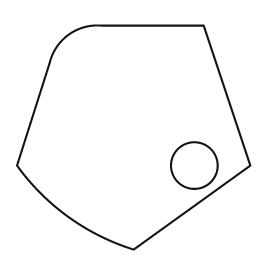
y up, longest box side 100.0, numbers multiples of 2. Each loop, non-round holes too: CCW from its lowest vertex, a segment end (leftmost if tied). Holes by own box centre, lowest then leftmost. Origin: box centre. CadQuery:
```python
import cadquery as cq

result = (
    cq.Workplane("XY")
    .moveTo(0.0, -48.0)
    .lineTo(50.0, -12.0)
    .lineTo(30.0, 48.0)
    .lineTo(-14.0, 48.0)
    .threePointArc((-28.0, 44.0), (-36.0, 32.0))
    .lineTo(-50.0, -12.0)
    .threePointArc((-28.0, -34.0), (0.0, -48.0))
    .close()
    .moveTo(26.0, -12.0)
    .circle(10.0)
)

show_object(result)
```